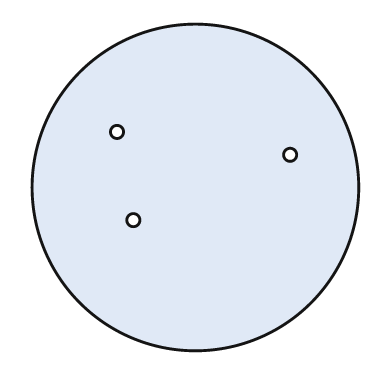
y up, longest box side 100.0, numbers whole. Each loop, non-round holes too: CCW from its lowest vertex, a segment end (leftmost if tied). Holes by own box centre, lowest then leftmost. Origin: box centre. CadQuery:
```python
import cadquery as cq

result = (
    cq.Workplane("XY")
    .moveTo(0.0, 0.0)
    .circle(50.0)
    .moveTo(-19.0, -10.0)
    .circle(2.0)
    .moveTo(29.0, 10.0)
    .circle(2.0)
    .moveTo(-24.0, 17.0)
    .circle(2.0)
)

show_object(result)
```